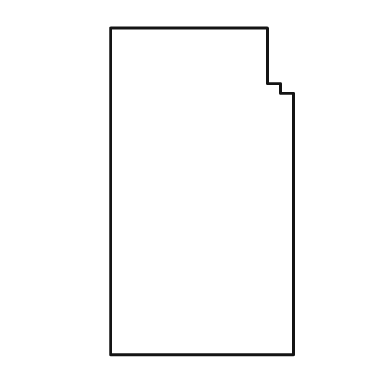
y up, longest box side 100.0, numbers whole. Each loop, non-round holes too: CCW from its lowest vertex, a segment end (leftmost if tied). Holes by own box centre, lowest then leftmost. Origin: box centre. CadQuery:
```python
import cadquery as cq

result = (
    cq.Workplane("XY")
    .moveTo(-28.0, -50.0)
    .lineTo(28.0, -50.0)
    .lineTo(28.0, 30.0)
    .lineTo(24.0, 30.0)
    .lineTo(24.0, 33.0)
    .lineTo(20.0, 33.0)
    .lineTo(20.0, 50.0)
    .lineTo(-28.0, 50.0)
    .close()
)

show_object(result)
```